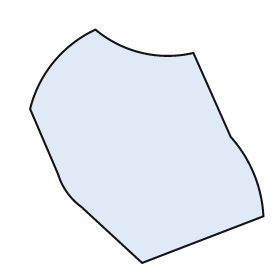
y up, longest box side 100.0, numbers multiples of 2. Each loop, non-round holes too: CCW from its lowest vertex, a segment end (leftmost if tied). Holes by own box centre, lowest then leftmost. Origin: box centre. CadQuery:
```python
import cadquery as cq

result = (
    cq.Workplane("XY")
    .moveTo(-2.0, -50.0)
    .lineTo(50.0, -30.0)
    .threePointArc((46.0, -12.0), (36.0, 4.0))
    .lineTo(20.0, 40.0)
    .threePointArc((-2.0, 40.0), (-22.0, 50.0))
    .threePointArc((-40.0, 36.0), (-50.0, 16.0))
    .lineTo(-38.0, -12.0)
    .threePointArc((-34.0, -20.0), (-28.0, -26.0))
    .close()
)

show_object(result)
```